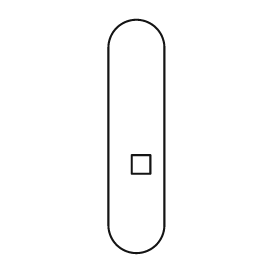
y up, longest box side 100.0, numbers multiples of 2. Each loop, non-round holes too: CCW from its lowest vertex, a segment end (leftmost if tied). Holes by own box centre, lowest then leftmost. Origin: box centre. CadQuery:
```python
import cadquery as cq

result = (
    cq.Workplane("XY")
    .moveTo(-12.0, -38.0)
    .threePointArc((0.0, -50.0), (12.0, -38.0))
    .lineTo(12.0, 38.0)
    .threePointArc((0.0, 50.0), (-12.0, 38.0))
    .close()
    .moveTo(-2.0, -16.0)
    .lineTo(6.0, -16.0)
    .lineTo(6.0, -8.0)
    .lineTo(-2.0, -8.0)
    .close()
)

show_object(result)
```